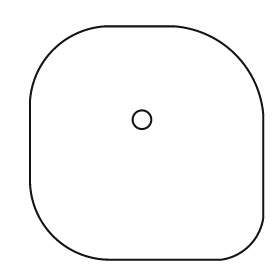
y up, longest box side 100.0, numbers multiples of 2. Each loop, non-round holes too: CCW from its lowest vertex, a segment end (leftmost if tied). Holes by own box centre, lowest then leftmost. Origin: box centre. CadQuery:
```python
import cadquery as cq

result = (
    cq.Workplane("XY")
    .moveTo(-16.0, -50.0)
    .lineTo(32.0, -50.0)
    .threePointArc((44.0, -44.0), (50.0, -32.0))
    .lineTo(50.0, 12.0)
    .threePointArc((38.0, 38.0), (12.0, 50.0))
    .lineTo(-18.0, 50.0)
    .threePointArc((-40.0, 40.0), (-50.0, 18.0))
    .lineTo(-50.0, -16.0)
    .threePointArc((-40.0, -40.0), (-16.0, -50.0))
    .close()
    .moveTo(-2.0, 10.0)
    .circle(4.0)
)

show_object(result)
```